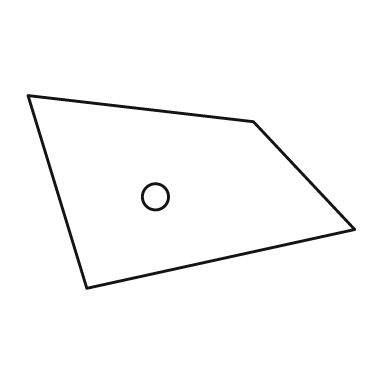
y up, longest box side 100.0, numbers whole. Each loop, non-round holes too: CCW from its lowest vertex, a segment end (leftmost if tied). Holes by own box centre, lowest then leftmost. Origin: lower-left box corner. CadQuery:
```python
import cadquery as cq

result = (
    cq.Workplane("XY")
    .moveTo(18.0, 0.0)
    .lineTo(100.0, 18.0)
    .lineTo(69.0, 51.0)
    .lineTo(0.0, 59.0)
    .close()
    .moveTo(39.0, 28.0)
    .circle(4.0)
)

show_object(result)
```